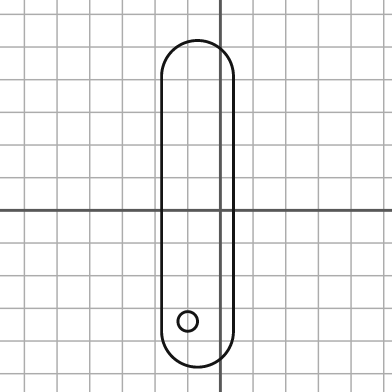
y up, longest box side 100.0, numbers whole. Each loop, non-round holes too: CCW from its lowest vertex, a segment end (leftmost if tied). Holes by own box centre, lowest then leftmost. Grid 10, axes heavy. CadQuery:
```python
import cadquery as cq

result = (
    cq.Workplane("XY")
    .moveTo(-18.0, -37.0)
    .threePointArc((-7.0, -48.0), (4.0, -37.0))
    .lineTo(4.0, 41.0)
    .threePointArc((-7.0, 52.0), (-18.0, 41.0))
    .close()
    .moveTo(-10.0, -34.0)
    .circle(3.0)
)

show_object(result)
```